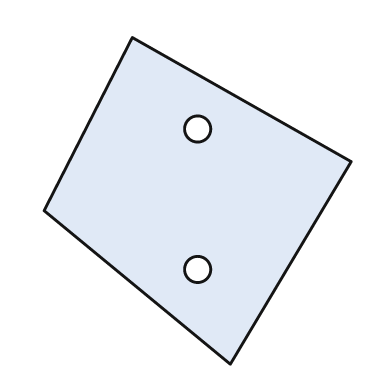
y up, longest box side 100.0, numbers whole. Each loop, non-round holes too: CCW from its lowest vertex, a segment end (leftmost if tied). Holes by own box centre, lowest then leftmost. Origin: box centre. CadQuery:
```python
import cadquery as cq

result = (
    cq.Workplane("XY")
    .moveTo(10.0, -50.0)
    .lineTo(47.0, 12.0)
    .lineTo(-20.0, 50.0)
    .lineTo(-47.0, -3.0)
    .close()
    .moveTo(0.0, -21.0)
    .circle(4.0)
    .moveTo(0.0, 22.0)
    .circle(4.0)
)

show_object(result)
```